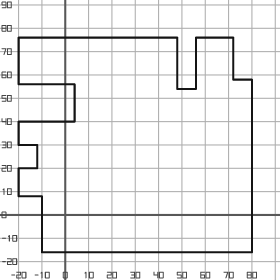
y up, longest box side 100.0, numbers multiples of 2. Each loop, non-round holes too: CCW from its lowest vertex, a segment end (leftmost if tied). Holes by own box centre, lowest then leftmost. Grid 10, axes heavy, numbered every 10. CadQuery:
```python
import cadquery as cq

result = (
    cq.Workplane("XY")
    .moveTo(-10.0, -16.0)
    .lineTo(80.0, -16.0)
    .lineTo(80.0, 58.0)
    .lineTo(72.0, 58.0)
    .lineTo(72.0, 76.0)
    .lineTo(56.0, 76.0)
    .lineTo(56.0, 54.0)
    .lineTo(48.0, 54.0)
    .lineTo(48.0, 76.0)
    .lineTo(-20.0, 76.0)
    .lineTo(-20.0, 56.0)
    .lineTo(4.0, 56.0)
    .lineTo(4.0, 40.0)
    .lineTo(-20.0, 40.0)
    .lineTo(-20.0, 30.0)
    .lineTo(-12.0, 30.0)
    .lineTo(-12.0, 20.0)
    .lineTo(-20.0, 20.0)
    .lineTo(-20.0, 8.0)
    .lineTo(-10.0, 8.0)
    .close()
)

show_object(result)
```